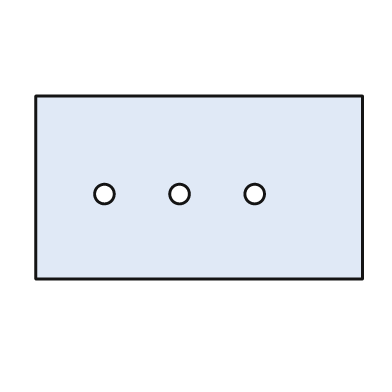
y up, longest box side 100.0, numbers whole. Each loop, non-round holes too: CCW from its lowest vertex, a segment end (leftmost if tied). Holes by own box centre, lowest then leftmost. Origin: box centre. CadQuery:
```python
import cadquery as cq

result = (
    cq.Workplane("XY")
    .moveTo(-50.0, -28.0)
    .lineTo(50.0, -28.0)
    .lineTo(50.0, 28.0)
    .lineTo(-50.0, 28.0)
    .close()
    .moveTo(-29.0, -2.0)
    .circle(3.0)
    .moveTo(-6.0, -2.0)
    .circle(3.0)
    .moveTo(17.0, -2.0)
    .circle(3.0)
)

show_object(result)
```